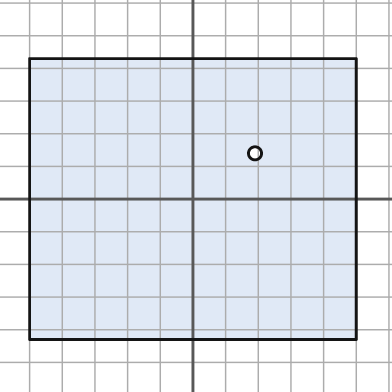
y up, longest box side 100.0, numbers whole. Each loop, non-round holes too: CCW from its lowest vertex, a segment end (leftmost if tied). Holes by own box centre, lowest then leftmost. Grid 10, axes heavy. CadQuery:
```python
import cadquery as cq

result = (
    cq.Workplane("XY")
    .moveTo(-50.0, -43.0)
    .lineTo(50.0, -43.0)
    .lineTo(50.0, 43.0)
    .lineTo(-50.0, 43.0)
    .close()
    .moveTo(19.0, 14.0)
    .circle(2.0)
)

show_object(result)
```